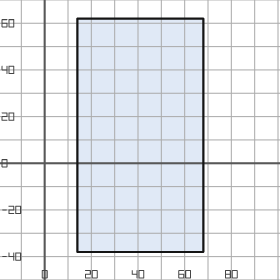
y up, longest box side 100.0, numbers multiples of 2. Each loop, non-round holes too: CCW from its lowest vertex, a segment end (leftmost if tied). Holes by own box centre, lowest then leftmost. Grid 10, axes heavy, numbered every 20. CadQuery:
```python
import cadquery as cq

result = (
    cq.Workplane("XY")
    .moveTo(14.0, -38.0)
    .lineTo(68.0, -38.0)
    .lineTo(68.0, 62.0)
    .lineTo(14.0, 62.0)
    .close()
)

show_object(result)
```